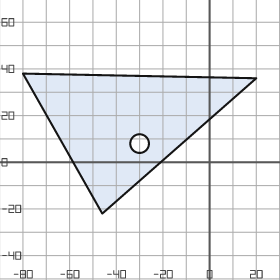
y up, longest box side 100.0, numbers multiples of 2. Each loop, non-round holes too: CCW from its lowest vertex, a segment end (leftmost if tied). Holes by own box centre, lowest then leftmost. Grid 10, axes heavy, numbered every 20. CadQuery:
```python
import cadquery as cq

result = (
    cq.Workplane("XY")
    .moveTo(-46.0, -22.0)
    .lineTo(20.0, 36.0)
    .lineTo(-80.0, 38.0)
    .close()
    .moveTo(-30.0, 8.0)
    .circle(4.0)
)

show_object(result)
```